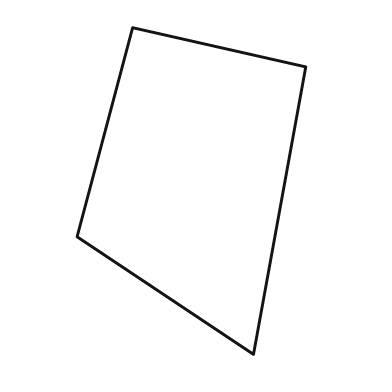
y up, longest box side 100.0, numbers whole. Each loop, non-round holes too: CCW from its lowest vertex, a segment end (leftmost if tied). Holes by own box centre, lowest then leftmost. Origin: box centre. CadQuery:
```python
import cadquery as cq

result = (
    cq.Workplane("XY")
    .moveTo(19.0, -50.0)
    .lineTo(35.0, 38.0)
    .lineTo(-18.0, 50.0)
    .lineTo(-35.0, -14.0)
    .close()
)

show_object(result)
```